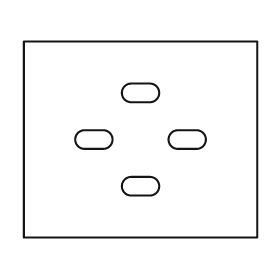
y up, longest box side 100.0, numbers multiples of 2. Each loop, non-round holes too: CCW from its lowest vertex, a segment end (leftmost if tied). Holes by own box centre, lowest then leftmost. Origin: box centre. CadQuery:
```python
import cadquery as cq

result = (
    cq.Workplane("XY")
    .moveTo(-50.0, -42.0)
    .lineTo(50.0, -42.0)
    .lineTo(50.0, 42.0)
    .lineTo(-50.0, 42.0)
    .close()
    .moveTo(-4.0, -24.0)
    .lineTo(4.0, -24.0)
    .threePointArc((8.0, -20.0), (4.0, -16.0))
    .lineTo(-4.0, -16.0)
    .threePointArc((-8.0, -20.0), (-4.0, -24.0))
    .close()
    .moveTo(-24.0, -4.0)
    .lineTo(-16.0, -4.0)
    .threePointArc((-12.0, 0.0), (-16.0, 4.0))
    .lineTo(-24.0, 4.0)
    .threePointArc((-28.0, 0.0), (-24.0, -4.0))
    .close()
    .moveTo(16.0, -4.0)
    .lineTo(24.0, -4.0)
    .threePointArc((28.0, 0.0), (24.0, 4.0))
    .lineTo(16.0, 4.0)
    .threePointArc((12.0, 0.0), (16.0, -4.0))
    .close()
    .moveTo(-4.0, 16.0)
    .lineTo(4.0, 16.0)
    .threePointArc((8.0, 20.0), (4.0, 24.0))
    .lineTo(-4.0, 24.0)
    .threePointArc((-8.0, 20.0), (-4.0, 16.0))
    .close()
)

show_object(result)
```